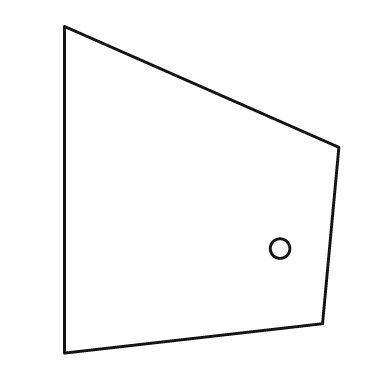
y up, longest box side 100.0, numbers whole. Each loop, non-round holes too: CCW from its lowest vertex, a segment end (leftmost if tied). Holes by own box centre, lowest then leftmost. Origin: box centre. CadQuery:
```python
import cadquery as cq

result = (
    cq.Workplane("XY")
    .moveTo(-42.0, -50.0)
    .lineTo(37.0, -41.0)
    .lineTo(42.0, 13.0)
    .lineTo(-42.0, 50.0)
    .close()
    .moveTo(24.0, -18.0)
    .circle(3.0)
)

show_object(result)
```